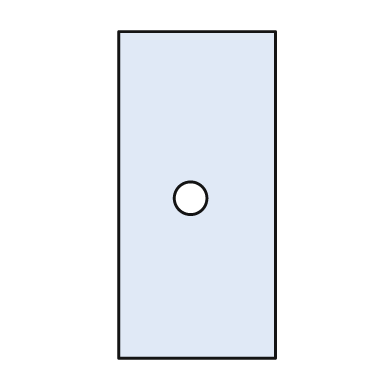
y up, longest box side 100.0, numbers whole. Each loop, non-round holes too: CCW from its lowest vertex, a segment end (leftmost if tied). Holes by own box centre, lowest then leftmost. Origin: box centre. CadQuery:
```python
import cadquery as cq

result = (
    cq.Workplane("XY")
    .moveTo(-24.0, -50.0)
    .lineTo(24.0, -50.0)
    .lineTo(24.0, 50.0)
    .lineTo(-24.0, 50.0)
    .close()
    .moveTo(-2.0, -1.0)
    .circle(5.0)
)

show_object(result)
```